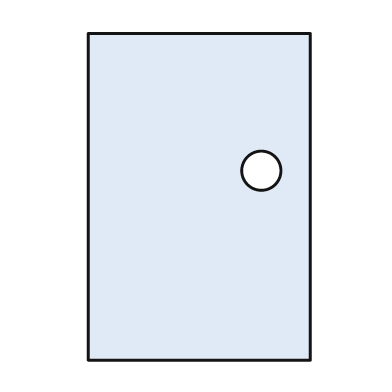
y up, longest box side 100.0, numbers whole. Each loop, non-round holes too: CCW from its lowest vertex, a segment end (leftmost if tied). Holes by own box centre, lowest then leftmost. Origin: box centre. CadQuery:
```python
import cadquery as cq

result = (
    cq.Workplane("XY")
    .moveTo(-34.0, -50.0)
    .lineTo(34.0, -50.0)
    .lineTo(34.0, 50.0)
    .lineTo(-34.0, 50.0)
    .close()
    .moveTo(19.0, 8.0)
    .circle(6.0)
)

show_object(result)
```